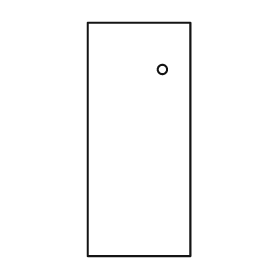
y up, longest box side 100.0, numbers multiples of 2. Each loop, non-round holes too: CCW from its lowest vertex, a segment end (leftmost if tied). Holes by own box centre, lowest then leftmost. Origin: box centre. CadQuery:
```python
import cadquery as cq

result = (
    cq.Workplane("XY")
    .moveTo(-22.0, -50.0)
    .lineTo(22.0, -50.0)
    .lineTo(22.0, 50.0)
    .lineTo(-22.0, 50.0)
    .close()
    .moveTo(10.0, 30.0)
    .circle(2.0)
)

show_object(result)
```